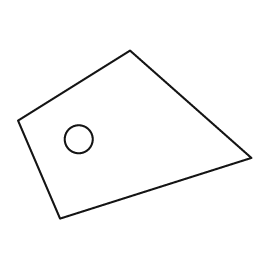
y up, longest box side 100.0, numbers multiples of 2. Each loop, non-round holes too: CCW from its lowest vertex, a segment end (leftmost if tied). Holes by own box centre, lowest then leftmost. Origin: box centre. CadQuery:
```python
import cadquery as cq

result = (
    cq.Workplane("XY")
    .moveTo(-32.0, -36.0)
    .lineTo(50.0, -10.0)
    .lineTo(-2.0, 36.0)
    .lineTo(-50.0, 6.0)
    .close()
    .moveTo(-24.0, -2.0)
    .circle(6.0)
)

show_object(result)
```